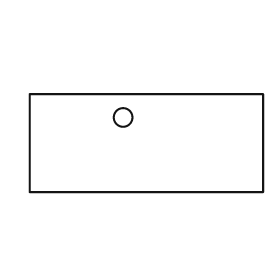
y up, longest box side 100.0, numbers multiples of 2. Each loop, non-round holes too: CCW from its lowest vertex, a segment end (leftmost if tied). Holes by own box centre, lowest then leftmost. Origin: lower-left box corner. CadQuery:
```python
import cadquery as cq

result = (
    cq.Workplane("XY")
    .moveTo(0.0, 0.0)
    .lineTo(100.0, 0.0)
    .lineTo(100.0, 42.0)
    .lineTo(0.0, 42.0)
    .close()
    .moveTo(40.0, 32.0)
    .circle(4.0)
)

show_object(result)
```